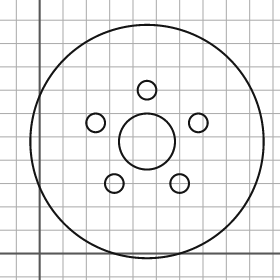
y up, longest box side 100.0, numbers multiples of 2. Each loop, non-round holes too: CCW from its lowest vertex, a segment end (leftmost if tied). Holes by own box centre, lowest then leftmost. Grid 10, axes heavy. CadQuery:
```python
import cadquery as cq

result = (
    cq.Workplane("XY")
    .moveTo(46.0, 48.0)
    .circle(50.0)
    .moveTo(32.0, 30.0)
    .circle(4.0)
    .moveTo(60.0, 30.0)
    .circle(4.0)
    .moveTo(46.0, 48.0)
    .circle(12.0)
    .moveTo(24.0, 56.0)
    .circle(4.0)
    .moveTo(68.0, 56.0)
    .circle(4.0)
    .moveTo(46.0, 70.0)
    .circle(4.0)
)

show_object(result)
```